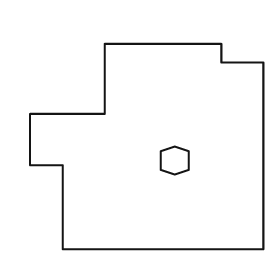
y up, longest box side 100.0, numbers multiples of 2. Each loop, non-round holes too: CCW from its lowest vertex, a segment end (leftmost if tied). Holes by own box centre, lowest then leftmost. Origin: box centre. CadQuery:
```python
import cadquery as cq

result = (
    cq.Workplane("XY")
    .moveTo(-36.0, -44.0)
    .lineTo(50.0, -44.0)
    .lineTo(50.0, 36.0)
    .lineTo(32.0, 36.0)
    .lineTo(32.0, 44.0)
    .lineTo(-18.0, 44.0)
    .lineTo(-18.0, 14.0)
    .lineTo(-50.0, 14.0)
    .lineTo(-50.0, -8.0)
    .lineTo(-36.0, -8.0)
    .close()
    .moveTo(12.0, -12.0)
    .lineTo(18.0, -10.0)
    .lineTo(18.0, -2.0)
    .lineTo(12.0, 0.0)
    .lineTo(6.0, -2.0)
    .lineTo(6.0, -10.0)
    .close()
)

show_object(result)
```